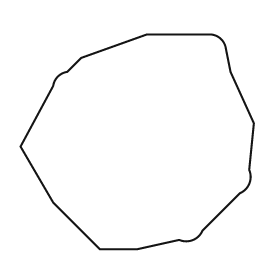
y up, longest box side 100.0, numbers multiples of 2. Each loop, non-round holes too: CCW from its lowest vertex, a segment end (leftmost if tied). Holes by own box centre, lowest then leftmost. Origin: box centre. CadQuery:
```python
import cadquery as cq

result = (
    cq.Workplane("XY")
    .moveTo(-16.0, -46.0)
    .lineTo(0.0, -46.0)
    .lineTo(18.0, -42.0)
    .threePointArc((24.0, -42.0), (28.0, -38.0))
    .lineTo(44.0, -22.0)
    .threePointArc((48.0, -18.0), (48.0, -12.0))
    .lineTo(50.0, 8.0)
    .lineTo(40.0, 30.0)
    .lineTo(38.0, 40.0)
    .threePointArc((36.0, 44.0), (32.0, 46.0))
    .lineTo(4.0, 46.0)
    .lineTo(-24.0, 36.0)
    .lineTo(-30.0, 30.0)
    .threePointArc((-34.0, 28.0), (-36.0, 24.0))
    .lineTo(-50.0, -2.0)
    .lineTo(-36.0, -26.0)
    .close()
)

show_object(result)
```